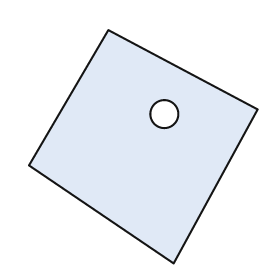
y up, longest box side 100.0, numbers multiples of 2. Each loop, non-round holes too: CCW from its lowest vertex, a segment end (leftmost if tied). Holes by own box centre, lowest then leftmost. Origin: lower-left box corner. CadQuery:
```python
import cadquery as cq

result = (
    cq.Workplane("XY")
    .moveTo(62.0, 0.0)
    .lineTo(98.0, 66.0)
    .lineTo(34.0, 100.0)
    .lineTo(0.0, 42.0)
    .close()
    .moveTo(58.0, 64.0)
    .circle(6.0)
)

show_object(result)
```